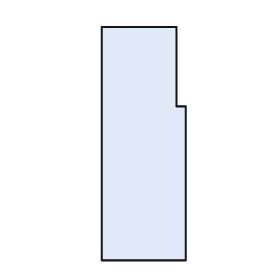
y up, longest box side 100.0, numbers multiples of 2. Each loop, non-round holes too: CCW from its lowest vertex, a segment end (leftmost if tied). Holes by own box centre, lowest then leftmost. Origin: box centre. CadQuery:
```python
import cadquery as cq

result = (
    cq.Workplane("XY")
    .moveTo(-18.0, -50.0)
    .lineTo(18.0, -50.0)
    .lineTo(18.0, 16.0)
    .lineTo(14.0, 16.0)
    .lineTo(14.0, 50.0)
    .lineTo(-18.0, 50.0)
    .close()
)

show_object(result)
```